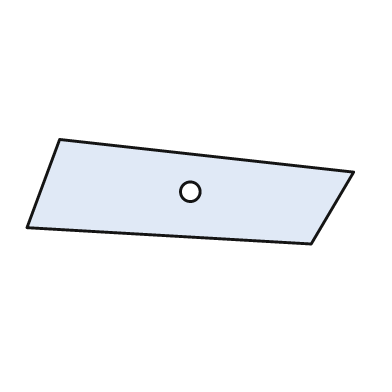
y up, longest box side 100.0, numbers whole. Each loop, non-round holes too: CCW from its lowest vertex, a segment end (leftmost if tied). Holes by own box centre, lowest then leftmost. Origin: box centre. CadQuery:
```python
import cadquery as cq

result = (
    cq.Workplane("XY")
    .moveTo(37.0, -16.0)
    .lineTo(50.0, 6.0)
    .lineTo(-40.0, 16.0)
    .lineTo(-50.0, -11.0)
    .close()
    .moveTo(0.0, 0.0)
    .circle(3.0)
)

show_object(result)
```